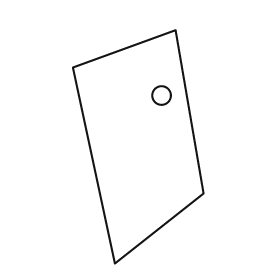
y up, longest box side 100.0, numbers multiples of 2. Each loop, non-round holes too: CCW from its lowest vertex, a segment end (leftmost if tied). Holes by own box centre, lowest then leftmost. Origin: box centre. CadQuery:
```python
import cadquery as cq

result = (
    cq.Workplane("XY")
    .moveTo(-10.0, -50.0)
    .lineTo(28.0, -20.0)
    .lineTo(16.0, 50.0)
    .lineTo(-28.0, 34.0)
    .close()
    .moveTo(10.0, 22.0)
    .circle(4.0)
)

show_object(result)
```